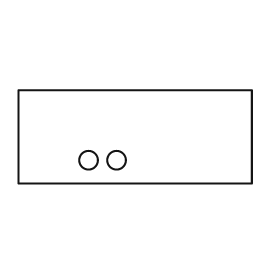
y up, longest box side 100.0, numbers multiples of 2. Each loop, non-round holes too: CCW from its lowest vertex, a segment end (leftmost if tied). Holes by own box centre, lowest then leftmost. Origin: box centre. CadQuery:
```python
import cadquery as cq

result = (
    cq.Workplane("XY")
    .moveTo(-50.0, -20.0)
    .lineTo(50.0, -20.0)
    .lineTo(50.0, 20.0)
    .lineTo(-50.0, 20.0)
    .close()
    .moveTo(-20.0, -10.0)
    .circle(4.0)
    .moveTo(-8.0, -10.0)
    .circle(4.0)
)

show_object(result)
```